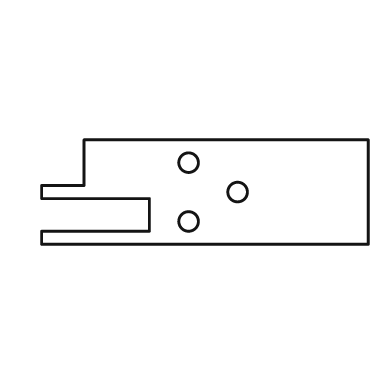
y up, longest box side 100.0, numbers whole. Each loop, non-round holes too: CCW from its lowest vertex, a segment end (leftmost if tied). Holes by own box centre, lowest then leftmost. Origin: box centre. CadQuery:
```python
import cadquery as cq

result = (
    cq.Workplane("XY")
    .moveTo(-50.0, -16.0)
    .lineTo(50.0, -16.0)
    .lineTo(50.0, 16.0)
    .lineTo(-37.0, 16.0)
    .lineTo(-37.0, 2.0)
    .lineTo(-50.0, 2.0)
    .lineTo(-50.0, -2.0)
    .lineTo(-17.0, -2.0)
    .lineTo(-17.0, -12.0)
    .lineTo(-50.0, -12.0)
    .close()
    .moveTo(-5.0, -9.0)
    .circle(3.0)
    .moveTo(10.0, 0.0)
    .circle(3.0)
    .moveTo(-5.0, 9.0)
    .circle(3.0)
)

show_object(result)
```